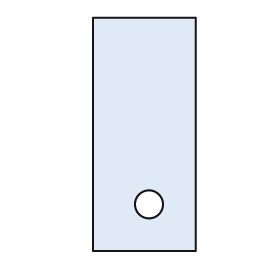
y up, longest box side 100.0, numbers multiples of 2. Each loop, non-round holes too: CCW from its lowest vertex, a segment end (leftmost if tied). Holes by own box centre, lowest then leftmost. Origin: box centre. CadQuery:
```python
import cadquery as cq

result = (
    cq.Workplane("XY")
    .moveTo(-22.0, -50.0)
    .lineTo(22.0, -50.0)
    .lineTo(22.0, 50.0)
    .lineTo(-22.0, 50.0)
    .close()
    .moveTo(2.0, -30.0)
    .circle(6.0)
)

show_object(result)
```